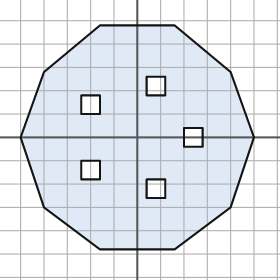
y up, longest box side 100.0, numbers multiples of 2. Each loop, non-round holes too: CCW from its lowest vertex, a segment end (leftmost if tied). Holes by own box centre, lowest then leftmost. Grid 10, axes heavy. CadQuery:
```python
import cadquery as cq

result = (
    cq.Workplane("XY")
    .moveTo(-16.0, -48.0)
    .lineTo(16.0, -48.0)
    .lineTo(40.0, -30.0)
    .lineTo(50.0, 0.0)
    .lineTo(40.0, 28.0)
    .lineTo(16.0, 48.0)
    .lineTo(-16.0, 48.0)
    .lineTo(-40.0, 28.0)
    .lineTo(-50.0, 0.0)
    .lineTo(-40.0, -30.0)
    .close()
    .moveTo(4.0, -26.0)
    .lineTo(12.0, -26.0)
    .lineTo(12.0, -18.0)
    .lineTo(4.0, -18.0)
    .close()
    .moveTo(-24.0, -18.0)
    .lineTo(-16.0, -18.0)
    .lineTo(-16.0, -10.0)
    .lineTo(-24.0, -10.0)
    .close()
    .moveTo(20.0, -4.0)
    .lineTo(28.0, -4.0)
    .lineTo(28.0, 4.0)
    .lineTo(20.0, 4.0)
    .close()
    .moveTo(-24.0, 10.0)
    .lineTo(-16.0, 10.0)
    .lineTo(-16.0, 18.0)
    .lineTo(-24.0, 18.0)
    .close()
    .moveTo(4.0, 18.0)
    .lineTo(12.0, 18.0)
    .lineTo(12.0, 26.0)
    .lineTo(4.0, 26.0)
    .close()
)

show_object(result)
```